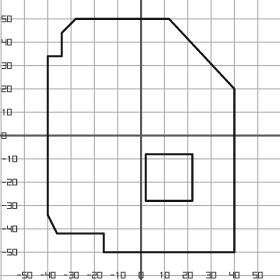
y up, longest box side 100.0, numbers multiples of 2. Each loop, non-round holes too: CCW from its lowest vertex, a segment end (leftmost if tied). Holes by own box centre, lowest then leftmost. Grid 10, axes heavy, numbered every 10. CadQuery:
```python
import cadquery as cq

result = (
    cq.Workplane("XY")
    .moveTo(-16.0, -50.0)
    .lineTo(40.0, -50.0)
    .lineTo(40.0, 20.0)
    .lineTo(12.0, 50.0)
    .lineTo(-28.0, 50.0)
    .lineTo(-34.0, 44.0)
    .lineTo(-34.0, 34.0)
    .lineTo(-40.0, 34.0)
    .lineTo(-40.0, -34.0)
    .lineTo(-36.0, -42.0)
    .lineTo(-16.0, -42.0)
    .close()
    .moveTo(2.0, -28.0)
    .lineTo(22.0, -28.0)
    .lineTo(22.0, -8.0)
    .lineTo(2.0, -8.0)
    .close()
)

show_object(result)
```